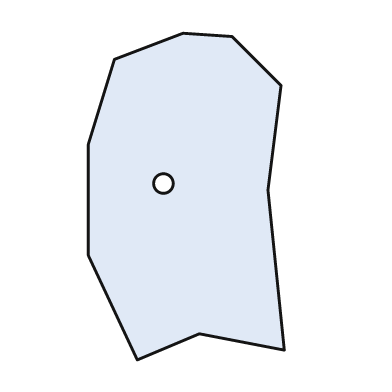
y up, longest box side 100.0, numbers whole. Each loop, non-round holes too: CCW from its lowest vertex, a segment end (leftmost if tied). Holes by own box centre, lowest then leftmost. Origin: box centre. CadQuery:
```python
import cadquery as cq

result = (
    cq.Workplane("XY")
    .moveTo(-15.0, -50.0)
    .lineTo(4.0, -42.0)
    .lineTo(30.0, -47.0)
    .lineTo(25.0, 2.0)
    .lineTo(29.0, 34.0)
    .lineTo(14.0, 49.0)
    .lineTo(-1.0, 50.0)
    .lineTo(-22.0, 42.0)
    .lineTo(-30.0, 16.0)
    .lineTo(-30.0, -18.0)
    .close()
    .moveTo(-7.0, 4.0)
    .circle(3.0)
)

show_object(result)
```